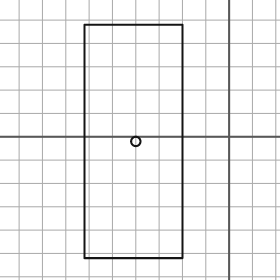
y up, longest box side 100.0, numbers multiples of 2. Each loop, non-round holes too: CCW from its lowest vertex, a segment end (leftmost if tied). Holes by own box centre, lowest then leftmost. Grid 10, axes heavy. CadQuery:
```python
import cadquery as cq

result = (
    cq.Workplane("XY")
    .moveTo(-62.0, -52.0)
    .lineTo(-20.0, -52.0)
    .lineTo(-20.0, 48.0)
    .lineTo(-62.0, 48.0)
    .close()
    .moveTo(-40.0, -2.0)
    .circle(2.0)
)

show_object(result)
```